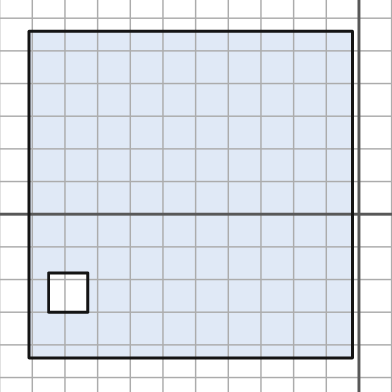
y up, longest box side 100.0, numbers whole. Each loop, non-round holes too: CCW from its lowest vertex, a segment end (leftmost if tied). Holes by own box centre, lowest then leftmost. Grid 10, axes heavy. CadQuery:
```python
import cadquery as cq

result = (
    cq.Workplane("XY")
    .moveTo(-101.0, -44.0)
    .lineTo(-2.0, -44.0)
    .lineTo(-2.0, 56.0)
    .lineTo(-101.0, 56.0)
    .close()
    .moveTo(-95.0, -30.0)
    .lineTo(-83.0, -30.0)
    .lineTo(-83.0, -18.0)
    .lineTo(-95.0, -18.0)
    .close()
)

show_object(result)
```